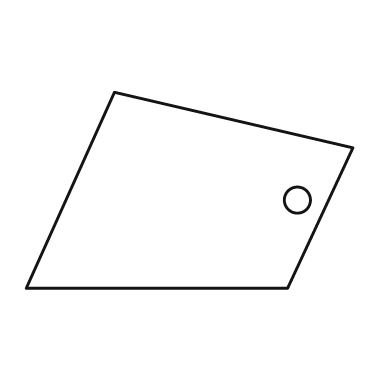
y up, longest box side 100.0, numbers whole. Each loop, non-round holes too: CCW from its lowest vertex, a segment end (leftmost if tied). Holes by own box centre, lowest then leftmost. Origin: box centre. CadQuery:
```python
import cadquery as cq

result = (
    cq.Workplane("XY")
    .moveTo(-50.0, -30.0)
    .lineTo(30.0, -30.0)
    .lineTo(50.0, 13.0)
    .lineTo(-23.0, 30.0)
    .close()
    .moveTo(33.0, -3.0)
    .circle(4.0)
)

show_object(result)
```